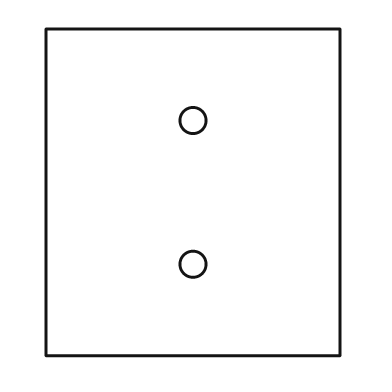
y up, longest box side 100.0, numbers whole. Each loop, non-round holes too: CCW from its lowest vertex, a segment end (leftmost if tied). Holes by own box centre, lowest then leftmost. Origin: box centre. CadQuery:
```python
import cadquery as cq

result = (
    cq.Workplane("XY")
    .moveTo(-45.0, -50.0)
    .lineTo(45.0, -50.0)
    .lineTo(45.0, 50.0)
    .lineTo(-45.0, 50.0)
    .close()
    .moveTo(0.0, -22.0)
    .circle(4.0)
    .moveTo(0.0, 22.0)
    .circle(4.0)
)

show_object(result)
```